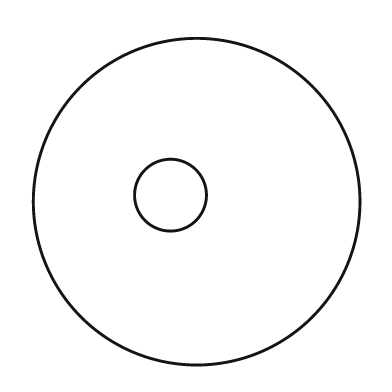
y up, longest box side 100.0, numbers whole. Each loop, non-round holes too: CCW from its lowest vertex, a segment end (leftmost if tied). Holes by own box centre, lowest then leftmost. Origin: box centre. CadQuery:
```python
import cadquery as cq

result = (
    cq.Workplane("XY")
    .moveTo(0.0, 0.0)
    .circle(50.0)
    .moveTo(-8.0, 2.0)
    .circle(11.0)
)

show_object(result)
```